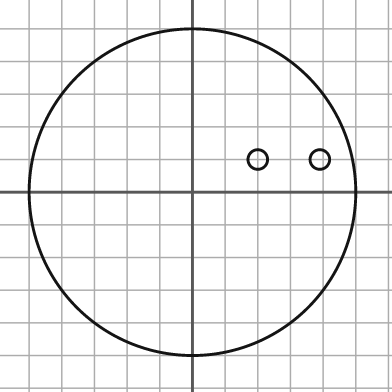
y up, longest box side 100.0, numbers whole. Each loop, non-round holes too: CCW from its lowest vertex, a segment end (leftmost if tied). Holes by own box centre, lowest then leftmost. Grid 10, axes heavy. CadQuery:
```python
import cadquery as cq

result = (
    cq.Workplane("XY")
    .moveTo(0.0, 0.0)
    .circle(50.0)
    .moveTo(20.0, 10.0)
    .circle(3.0)
    .moveTo(39.0, 10.0)
    .circle(3.0)
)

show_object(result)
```